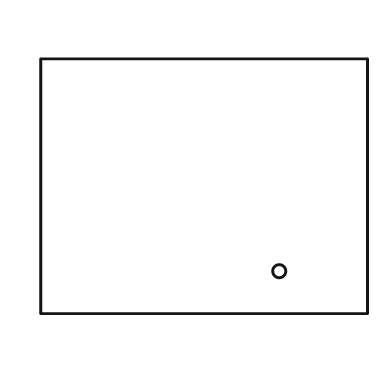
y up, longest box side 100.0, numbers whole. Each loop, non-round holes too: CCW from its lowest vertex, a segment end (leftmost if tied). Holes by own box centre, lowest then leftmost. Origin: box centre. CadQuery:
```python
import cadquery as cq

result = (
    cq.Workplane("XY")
    .moveTo(-50.0, -39.0)
    .lineTo(50.0, -39.0)
    .lineTo(50.0, 39.0)
    .lineTo(-50.0, 39.0)
    .close()
    .moveTo(23.0, -26.0)
    .circle(2.0)
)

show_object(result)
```